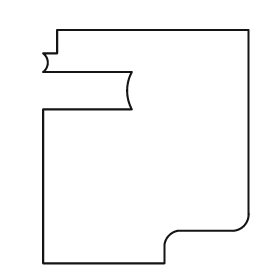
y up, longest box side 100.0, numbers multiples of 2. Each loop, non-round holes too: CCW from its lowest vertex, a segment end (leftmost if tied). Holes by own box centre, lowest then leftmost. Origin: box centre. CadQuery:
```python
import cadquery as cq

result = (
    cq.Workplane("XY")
    .moveTo(-44.0, -50.0)
    .lineTo(8.0, -50.0)
    .lineTo(8.0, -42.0)
    .threePointArc((10.0, -38.0), (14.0, -36.0))
    .lineTo(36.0, -36.0)
    .threePointArc((42.0, -34.0), (44.0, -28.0))
    .lineTo(44.0, 50.0)
    .lineTo(-38.0, 50.0)
    .lineTo(-38.0, 40.0)
    .lineTo(-44.0, 40.0)
    .threePointArc((-42.0, 36.0), (-44.0, 32.0))
    .lineTo(-6.0, 32.0)
    .threePointArc((-8.0, 24.0), (-6.0, 16.0))
    .lineTo(-44.0, 16.0)
    .close()
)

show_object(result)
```